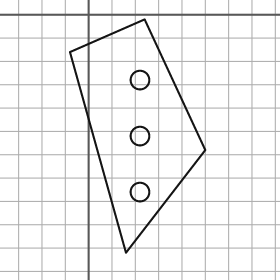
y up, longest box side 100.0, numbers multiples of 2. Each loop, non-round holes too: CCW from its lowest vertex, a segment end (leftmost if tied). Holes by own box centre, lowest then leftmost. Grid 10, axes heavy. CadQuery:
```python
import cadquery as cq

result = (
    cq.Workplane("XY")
    .moveTo(16.0, -102.0)
    .lineTo(50.0, -58.0)
    .lineTo(24.0, -2.0)
    .lineTo(-8.0, -16.0)
    .close()
    .moveTo(22.0, -76.0)
    .circle(4.0)
    .moveTo(22.0, -52.0)
    .circle(4.0)
    .moveTo(22.0, -28.0)
    .circle(4.0)
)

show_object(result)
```